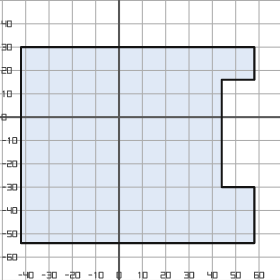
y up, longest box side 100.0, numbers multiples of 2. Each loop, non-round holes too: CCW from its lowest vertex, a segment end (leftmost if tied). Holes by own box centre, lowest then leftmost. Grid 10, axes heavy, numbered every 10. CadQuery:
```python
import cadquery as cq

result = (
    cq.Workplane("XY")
    .moveTo(-42.0, -54.0)
    .lineTo(58.0, -54.0)
    .lineTo(58.0, -30.0)
    .lineTo(44.0, -30.0)
    .lineTo(44.0, 16.0)
    .lineTo(58.0, 16.0)
    .lineTo(58.0, 30.0)
    .lineTo(-42.0, 30.0)
    .close()
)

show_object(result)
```